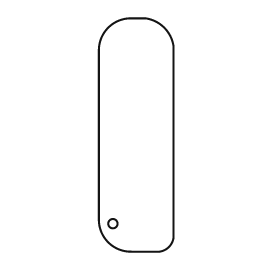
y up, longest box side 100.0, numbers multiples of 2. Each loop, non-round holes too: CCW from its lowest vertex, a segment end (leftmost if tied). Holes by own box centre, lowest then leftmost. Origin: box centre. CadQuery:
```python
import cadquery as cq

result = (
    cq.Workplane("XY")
    .moveTo(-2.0, -50.0)
    .lineTo(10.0, -50.0)
    .threePointArc((14.0, -48.0), (16.0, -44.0))
    .lineTo(16.0, 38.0)
    .threePointArc((12.0, 46.0), (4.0, 50.0))
    .lineTo(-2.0, 50.0)
    .threePointArc((-12.0, 46.0), (-16.0, 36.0))
    .lineTo(-16.0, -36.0)
    .threePointArc((-12.0, -46.0), (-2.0, -50.0))
    .close()
    .moveTo(-10.0, -38.0)
    .circle(2.0)
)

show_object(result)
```